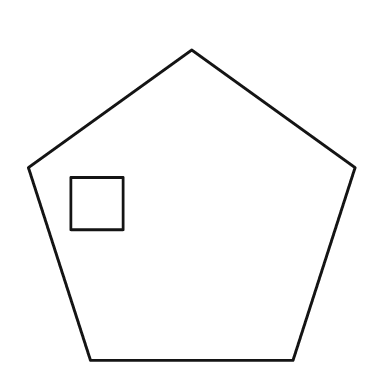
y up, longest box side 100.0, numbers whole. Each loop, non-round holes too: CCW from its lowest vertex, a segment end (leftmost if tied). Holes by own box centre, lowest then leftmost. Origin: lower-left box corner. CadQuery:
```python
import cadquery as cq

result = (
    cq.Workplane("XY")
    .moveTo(19.0, 0.0)
    .lineTo(81.0, 0.0)
    .lineTo(100.0, 59.0)
    .lineTo(50.0, 95.0)
    .lineTo(0.0, 59.0)
    .close()
    .moveTo(13.0, 40.0)
    .lineTo(29.0, 40.0)
    .lineTo(29.0, 56.0)
    .lineTo(13.0, 56.0)
    .close()
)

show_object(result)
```